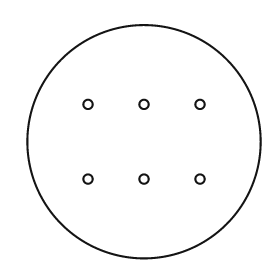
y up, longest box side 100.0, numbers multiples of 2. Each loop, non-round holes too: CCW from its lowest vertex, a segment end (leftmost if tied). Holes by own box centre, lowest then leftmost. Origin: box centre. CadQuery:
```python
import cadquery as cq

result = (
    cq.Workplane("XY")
    .moveTo(0.0, 0.0)
    .circle(50.0)
    .moveTo(-24.0, -16.0)
    .circle(2.0)
    .moveTo(0.0, -16.0)
    .circle(2.0)
    .moveTo(24.0, -16.0)
    .circle(2.0)
    .moveTo(-24.0, 16.0)
    .circle(2.0)
    .moveTo(0.0, 16.0)
    .circle(2.0)
    .moveTo(24.0, 16.0)
    .circle(2.0)
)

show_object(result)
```